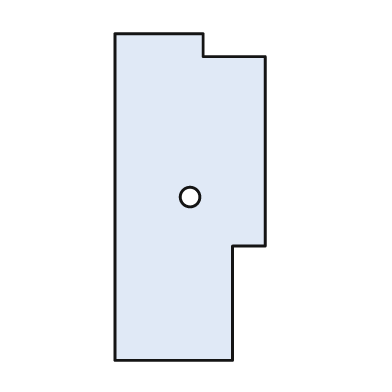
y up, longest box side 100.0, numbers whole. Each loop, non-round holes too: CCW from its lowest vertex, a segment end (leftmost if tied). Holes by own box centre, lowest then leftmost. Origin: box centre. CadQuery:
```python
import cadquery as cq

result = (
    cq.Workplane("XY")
    .moveTo(-23.0, -50.0)
    .lineTo(13.0, -50.0)
    .lineTo(13.0, -15.0)
    .lineTo(23.0, -15.0)
    .lineTo(23.0, 43.0)
    .lineTo(4.0, 43.0)
    .lineTo(4.0, 50.0)
    .lineTo(-23.0, 50.0)
    .close()
    .moveTo(0.0, 0.0)
    .circle(3.0)
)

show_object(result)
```